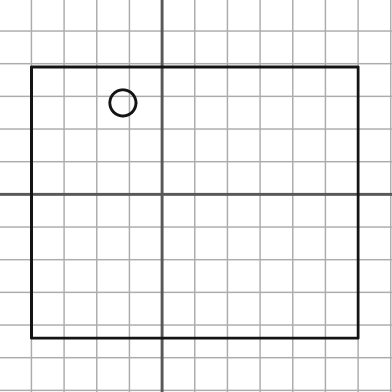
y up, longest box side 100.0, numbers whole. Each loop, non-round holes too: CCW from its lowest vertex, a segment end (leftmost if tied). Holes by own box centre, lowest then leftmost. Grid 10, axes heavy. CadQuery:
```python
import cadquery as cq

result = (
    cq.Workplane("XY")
    .moveTo(-40.0, -44.0)
    .lineTo(60.0, -44.0)
    .lineTo(60.0, 39.0)
    .lineTo(-40.0, 39.0)
    .close()
    .moveTo(-12.0, 28.0)
    .circle(4.0)
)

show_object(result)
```